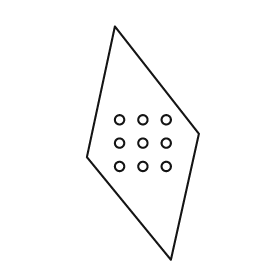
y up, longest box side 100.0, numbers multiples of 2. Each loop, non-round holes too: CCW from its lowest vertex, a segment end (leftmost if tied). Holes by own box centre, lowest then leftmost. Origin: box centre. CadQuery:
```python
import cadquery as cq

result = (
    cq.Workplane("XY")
    .moveTo(12.0, -50.0)
    .lineTo(24.0, 4.0)
    .lineTo(-12.0, 50.0)
    .lineTo(-24.0, -6.0)
    .close()
    .moveTo(-10.0, -10.0)
    .circle(2.0)
    .moveTo(0.0, -10.0)
    .circle(2.0)
    .moveTo(10.0, -10.0)
    .circle(2.0)
    .moveTo(-10.0, 0.0)
    .circle(2.0)
    .moveTo(0.0, 0.0)
    .circle(2.0)
    .moveTo(10.0, 0.0)
    .circle(2.0)
    .moveTo(-10.0, 10.0)
    .circle(2.0)
    .moveTo(0.0, 10.0)
    .circle(2.0)
    .moveTo(10.0, 10.0)
    .circle(2.0)
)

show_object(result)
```